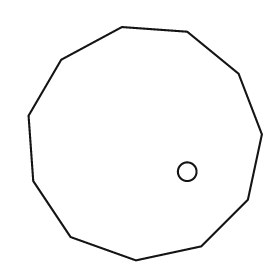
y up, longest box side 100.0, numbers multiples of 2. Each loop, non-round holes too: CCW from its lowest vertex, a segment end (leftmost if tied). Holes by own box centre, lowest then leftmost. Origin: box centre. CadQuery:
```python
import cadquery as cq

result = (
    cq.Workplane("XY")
    .moveTo(-4.0, -50.0)
    .lineTo(24.0, -44.0)
    .lineTo(44.0, -24.0)
    .lineTo(50.0, 4.0)
    .lineTo(40.0, 30.0)
    .lineTo(18.0, 48.0)
    .lineTo(-10.0, 50.0)
    .lineTo(-36.0, 36.0)
    .lineTo(-50.0, 12.0)
    .lineTo(-48.0, -16.0)
    .lineTo(-32.0, -40.0)
    .close()
    .moveTo(18.0, -12.0)
    .circle(4.0)
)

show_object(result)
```